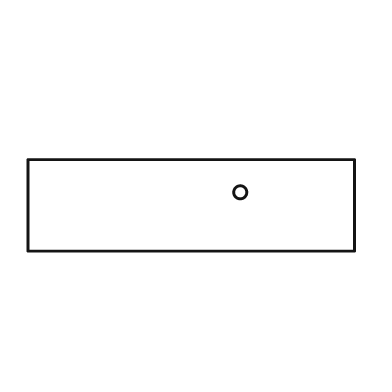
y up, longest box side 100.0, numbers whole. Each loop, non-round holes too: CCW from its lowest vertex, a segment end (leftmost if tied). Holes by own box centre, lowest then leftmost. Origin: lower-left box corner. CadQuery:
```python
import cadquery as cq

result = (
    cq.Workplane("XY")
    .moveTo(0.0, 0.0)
    .lineTo(100.0, 0.0)
    .lineTo(100.0, 28.0)
    .lineTo(0.0, 28.0)
    .close()
    .moveTo(65.0, 18.0)
    .circle(2.0)
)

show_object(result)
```